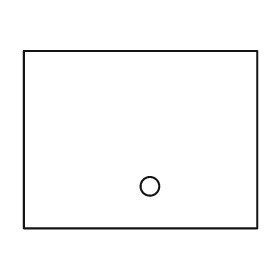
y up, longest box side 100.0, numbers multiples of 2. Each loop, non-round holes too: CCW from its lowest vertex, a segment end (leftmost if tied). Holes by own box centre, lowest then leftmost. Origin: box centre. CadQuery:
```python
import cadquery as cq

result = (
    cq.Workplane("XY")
    .moveTo(-50.0, -38.0)
    .lineTo(50.0, -38.0)
    .lineTo(50.0, 38.0)
    .lineTo(-50.0, 38.0)
    .close()
    .moveTo(4.0, -20.0)
    .circle(4.0)
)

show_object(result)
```